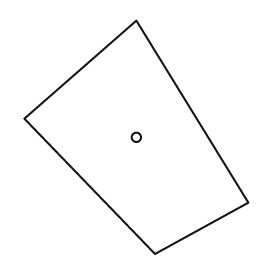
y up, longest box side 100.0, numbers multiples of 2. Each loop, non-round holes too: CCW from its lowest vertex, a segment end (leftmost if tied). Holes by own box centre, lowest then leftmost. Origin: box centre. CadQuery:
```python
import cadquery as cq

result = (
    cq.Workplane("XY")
    .moveTo(8.0, -50.0)
    .lineTo(48.0, -28.0)
    .lineTo(0.0, 50.0)
    .lineTo(-48.0, 8.0)
    .close()
    .moveTo(0.0, 0.0)
    .circle(2.0)
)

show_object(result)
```